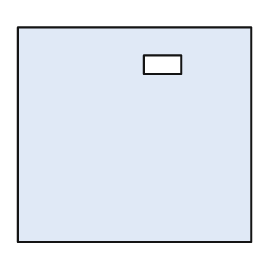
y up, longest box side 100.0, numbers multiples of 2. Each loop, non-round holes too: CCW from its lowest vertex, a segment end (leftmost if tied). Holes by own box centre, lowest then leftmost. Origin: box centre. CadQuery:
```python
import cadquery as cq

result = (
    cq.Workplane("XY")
    .moveTo(-50.0, -46.0)
    .lineTo(50.0, -46.0)
    .lineTo(50.0, 46.0)
    .lineTo(-50.0, 46.0)
    .close()
    .moveTo(4.0, 26.0)
    .lineTo(20.0, 26.0)
    .lineTo(20.0, 34.0)
    .lineTo(4.0, 34.0)
    .close()
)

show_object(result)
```